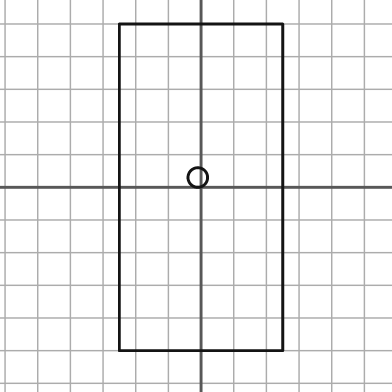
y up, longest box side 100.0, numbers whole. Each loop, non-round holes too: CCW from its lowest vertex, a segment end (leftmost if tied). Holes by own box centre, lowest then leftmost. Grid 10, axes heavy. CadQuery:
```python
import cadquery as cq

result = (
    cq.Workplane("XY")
    .moveTo(-25.0, -50.0)
    .lineTo(25.0, -50.0)
    .lineTo(25.0, 50.0)
    .lineTo(-25.0, 50.0)
    .close()
    .moveTo(-1.0, 3.0)
    .circle(3.0)
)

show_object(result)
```